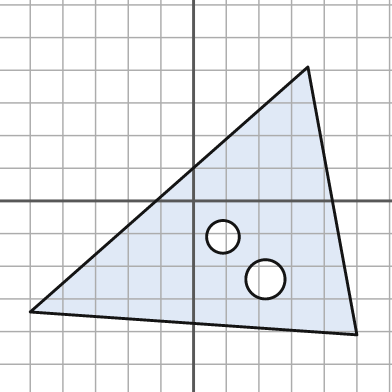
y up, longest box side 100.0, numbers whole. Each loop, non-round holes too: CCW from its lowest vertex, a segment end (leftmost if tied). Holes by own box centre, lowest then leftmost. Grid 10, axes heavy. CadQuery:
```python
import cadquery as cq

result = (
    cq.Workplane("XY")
    .moveTo(50.0, -41.0)
    .lineTo(35.0, 41.0)
    .lineTo(-50.0, -34.0)
    .close()
    .moveTo(22.0, -24.0)
    .circle(6.0)
    .moveTo(9.0, -11.0)
    .circle(5.0)
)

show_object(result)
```